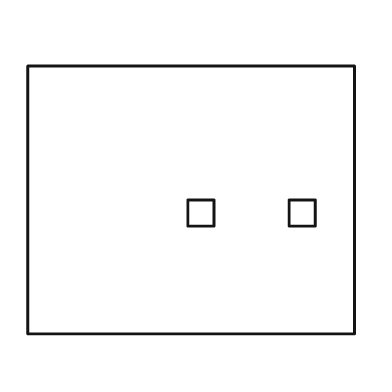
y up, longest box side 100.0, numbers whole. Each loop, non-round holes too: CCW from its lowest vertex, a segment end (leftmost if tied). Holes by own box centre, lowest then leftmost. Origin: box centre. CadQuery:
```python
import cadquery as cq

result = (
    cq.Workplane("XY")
    .moveTo(-50.0, -41.0)
    .lineTo(50.0, -41.0)
    .lineTo(50.0, 41.0)
    .lineTo(-50.0, 41.0)
    .close()
    .moveTo(-1.0, -8.0)
    .lineTo(7.0, -8.0)
    .lineTo(7.0, 0.0)
    .lineTo(-1.0, 0.0)
    .close()
    .moveTo(30.0, -8.0)
    .lineTo(38.0, -8.0)
    .lineTo(38.0, 0.0)
    .lineTo(30.0, 0.0)
    .close()
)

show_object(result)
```